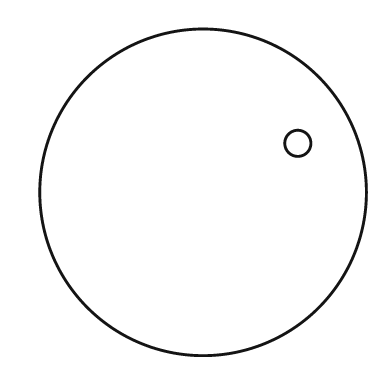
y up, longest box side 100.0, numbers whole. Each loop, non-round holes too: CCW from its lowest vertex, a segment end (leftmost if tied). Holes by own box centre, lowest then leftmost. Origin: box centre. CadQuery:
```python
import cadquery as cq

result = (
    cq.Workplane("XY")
    .moveTo(0.0, 0.0)
    .circle(50.0)
    .moveTo(29.0, 15.0)
    .circle(4.0)
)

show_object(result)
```